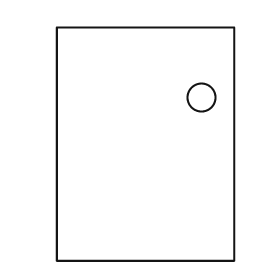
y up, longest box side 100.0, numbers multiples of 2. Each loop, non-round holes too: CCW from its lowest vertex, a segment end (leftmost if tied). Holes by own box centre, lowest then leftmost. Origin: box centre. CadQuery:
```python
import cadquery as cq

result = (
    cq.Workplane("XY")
    .moveTo(-38.0, -50.0)
    .lineTo(38.0, -50.0)
    .lineTo(38.0, 50.0)
    .lineTo(-38.0, 50.0)
    .close()
    .moveTo(24.0, 20.0)
    .circle(6.0)
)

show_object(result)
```